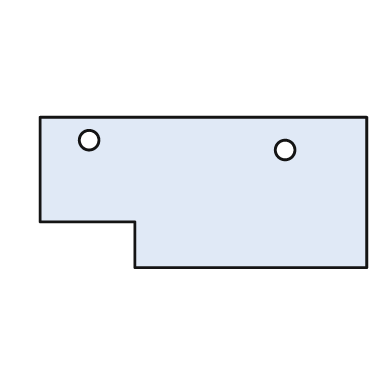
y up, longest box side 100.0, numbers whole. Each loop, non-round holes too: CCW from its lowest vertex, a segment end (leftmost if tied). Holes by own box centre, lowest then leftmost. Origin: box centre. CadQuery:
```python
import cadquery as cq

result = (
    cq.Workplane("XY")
    .moveTo(-21.0, -23.0)
    .lineTo(50.0, -23.0)
    .lineTo(50.0, 23.0)
    .lineTo(-50.0, 23.0)
    .lineTo(-50.0, -9.0)
    .lineTo(-21.0, -9.0)
    .close()
    .moveTo(25.0, 13.0)
    .circle(3.0)
    .moveTo(-35.0, 16.0)
    .circle(3.0)
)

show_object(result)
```